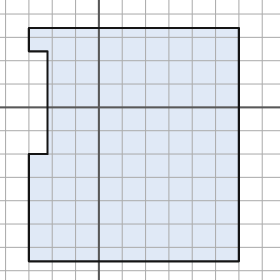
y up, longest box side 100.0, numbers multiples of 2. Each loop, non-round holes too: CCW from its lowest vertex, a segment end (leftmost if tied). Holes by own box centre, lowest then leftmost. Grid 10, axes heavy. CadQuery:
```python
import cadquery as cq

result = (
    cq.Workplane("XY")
    .moveTo(-30.0, -66.0)
    .lineTo(60.0, -66.0)
    .lineTo(60.0, 34.0)
    .lineTo(-30.0, 34.0)
    .lineTo(-30.0, 24.0)
    .lineTo(-22.0, 24.0)
    .lineTo(-22.0, -20.0)
    .lineTo(-30.0, -20.0)
    .close()
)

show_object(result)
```